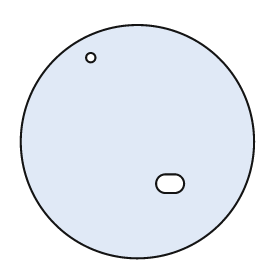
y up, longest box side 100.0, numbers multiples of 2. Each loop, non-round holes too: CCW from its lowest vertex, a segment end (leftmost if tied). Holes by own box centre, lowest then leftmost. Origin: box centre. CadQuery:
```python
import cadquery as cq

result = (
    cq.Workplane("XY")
    .moveTo(0.0, 0.0)
    .circle(50.0)
    .moveTo(12.0, -22.0)
    .lineTo(16.0, -22.0)
    .threePointArc((20.0, -18.0), (16.0, -14.0))
    .lineTo(12.0, -14.0)
    .threePointArc((8.0, -18.0), (12.0, -22.0))
    .close()
    .moveTo(-20.0, 36.0)
    .circle(2.0)
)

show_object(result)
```